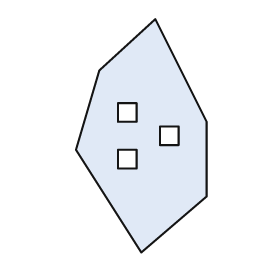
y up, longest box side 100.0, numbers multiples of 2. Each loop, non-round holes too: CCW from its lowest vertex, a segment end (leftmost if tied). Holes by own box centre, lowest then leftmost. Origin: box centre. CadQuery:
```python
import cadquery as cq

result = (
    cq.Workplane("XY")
    .moveTo(0.0, -50.0)
    .lineTo(28.0, -26.0)
    .lineTo(28.0, 6.0)
    .lineTo(6.0, 50.0)
    .lineTo(-18.0, 28.0)
    .lineTo(-28.0, -6.0)
    .close()
    .moveTo(-10.0, -14.0)
    .lineTo(-2.0, -14.0)
    .lineTo(-2.0, -6.0)
    .lineTo(-10.0, -6.0)
    .close()
    .moveTo(8.0, -4.0)
    .lineTo(16.0, -4.0)
    .lineTo(16.0, 4.0)
    .lineTo(8.0, 4.0)
    .close()
    .moveTo(-10.0, 6.0)
    .lineTo(-2.0, 6.0)
    .lineTo(-2.0, 14.0)
    .lineTo(-10.0, 14.0)
    .close()
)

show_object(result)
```